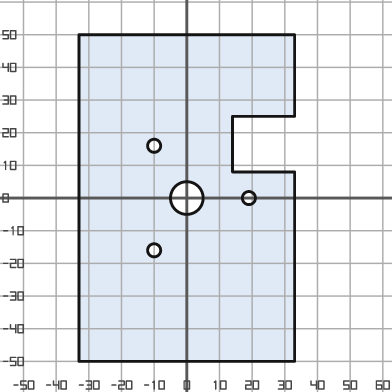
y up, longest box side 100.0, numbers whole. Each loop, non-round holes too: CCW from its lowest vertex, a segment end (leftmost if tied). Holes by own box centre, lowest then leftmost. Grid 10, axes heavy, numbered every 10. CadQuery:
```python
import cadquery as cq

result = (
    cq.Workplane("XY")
    .moveTo(-33.0, -50.0)
    .lineTo(33.0, -50.0)
    .lineTo(33.0, 8.0)
    .lineTo(14.0, 8.0)
    .lineTo(14.0, 25.0)
    .lineTo(33.0, 25.0)
    .lineTo(33.0, 50.0)
    .lineTo(-33.0, 50.0)
    .close()
    .moveTo(-10.0, -16.0)
    .circle(2.0)
    .moveTo(0.0, 0.0)
    .circle(5.0)
    .moveTo(19.0, 0.0)
    .circle(2.0)
    .moveTo(-10.0, 16.0)
    .circle(2.0)
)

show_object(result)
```